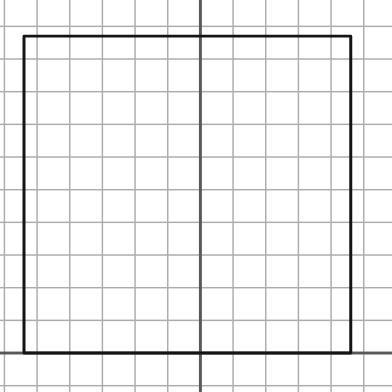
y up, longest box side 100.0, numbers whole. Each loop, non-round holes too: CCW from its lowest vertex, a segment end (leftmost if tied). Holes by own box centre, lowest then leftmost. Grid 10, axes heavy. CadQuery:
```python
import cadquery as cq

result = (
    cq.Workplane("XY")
    .moveTo(-54.0, 0.0)
    .lineTo(46.0, 0.0)
    .lineTo(46.0, 97.0)
    .lineTo(-54.0, 97.0)
    .close()
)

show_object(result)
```